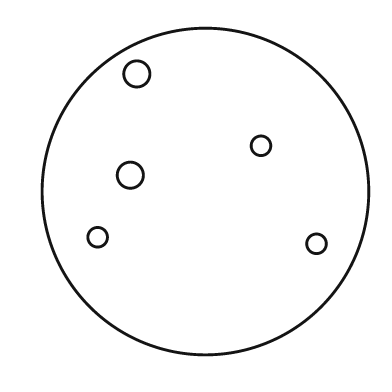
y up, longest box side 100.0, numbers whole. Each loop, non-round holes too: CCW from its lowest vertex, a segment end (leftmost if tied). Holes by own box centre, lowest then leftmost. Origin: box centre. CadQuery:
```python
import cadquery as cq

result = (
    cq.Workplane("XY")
    .moveTo(0.0, 0.0)
    .circle(50.0)
    .moveTo(34.0, -16.0)
    .circle(3.0)
    .moveTo(-33.0, -14.0)
    .circle(3.0)
    .moveTo(-23.0, 5.0)
    .circle(4.0)
    .moveTo(17.0, 14.0)
    .circle(3.0)
    .moveTo(-21.0, 36.0)
    .circle(4.0)
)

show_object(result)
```